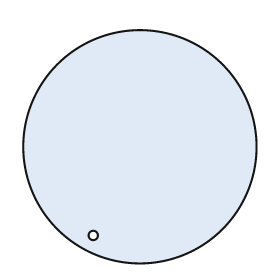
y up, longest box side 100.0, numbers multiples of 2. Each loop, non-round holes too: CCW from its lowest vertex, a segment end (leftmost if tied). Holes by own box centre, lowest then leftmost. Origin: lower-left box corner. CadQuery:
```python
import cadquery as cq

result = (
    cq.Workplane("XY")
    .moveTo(50.0, 50.0)
    .circle(50.0)
    .moveTo(30.0, 12.0)
    .circle(2.0)
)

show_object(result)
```